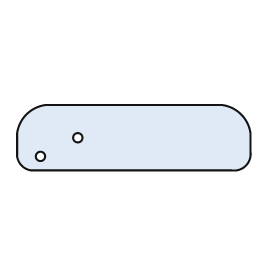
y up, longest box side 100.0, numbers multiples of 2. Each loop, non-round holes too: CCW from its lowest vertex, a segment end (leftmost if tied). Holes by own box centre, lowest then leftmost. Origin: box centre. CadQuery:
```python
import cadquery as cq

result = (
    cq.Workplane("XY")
    .moveTo(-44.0, -14.0)
    .lineTo(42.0, -14.0)
    .threePointArc((48.0, -12.0), (50.0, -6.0))
    .lineTo(50.0, 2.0)
    .threePointArc((46.0, 10.0), (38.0, 14.0))
    .lineTo(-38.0, 14.0)
    .threePointArc((-46.0, 10.0), (-50.0, 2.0))
    .lineTo(-50.0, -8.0)
    .threePointArc((-48.0, -12.0), (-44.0, -14.0))
    .close()
    .moveTo(-40.0, -8.0)
    .circle(2.0)
    .moveTo(-24.0, 0.0)
    .circle(2.0)
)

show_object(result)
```